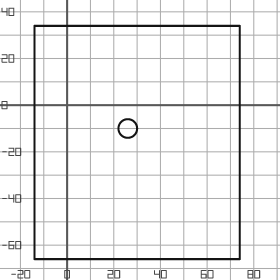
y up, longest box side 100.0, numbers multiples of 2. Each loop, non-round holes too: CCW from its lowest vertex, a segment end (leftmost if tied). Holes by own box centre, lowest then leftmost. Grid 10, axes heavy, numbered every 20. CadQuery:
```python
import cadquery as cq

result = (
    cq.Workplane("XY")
    .moveTo(-14.0, -66.0)
    .lineTo(74.0, -66.0)
    .lineTo(74.0, 34.0)
    .lineTo(-14.0, 34.0)
    .close()
    .moveTo(26.0, -10.0)
    .circle(4.0)
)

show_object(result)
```